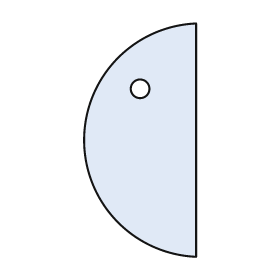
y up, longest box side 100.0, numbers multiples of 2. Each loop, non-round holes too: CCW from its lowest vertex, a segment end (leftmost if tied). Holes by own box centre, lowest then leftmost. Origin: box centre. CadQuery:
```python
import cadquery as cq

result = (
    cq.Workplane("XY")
    .moveTo(24.0, -50.0)
    .lineTo(24.0, 50.0)
    .threePointArc((-24.0, 0.0), (24.0, -50.0))
    .close()
    .moveTo(0.0, 22.0)
    .circle(4.0)
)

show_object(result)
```